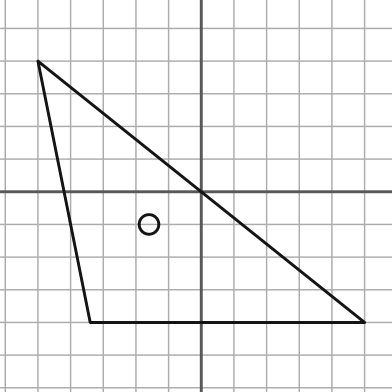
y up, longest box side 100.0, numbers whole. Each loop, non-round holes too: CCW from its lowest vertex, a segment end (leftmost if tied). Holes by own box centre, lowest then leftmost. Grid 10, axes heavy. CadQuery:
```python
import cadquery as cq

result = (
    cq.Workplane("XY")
    .moveTo(-34.0, -40.0)
    .lineTo(50.0, -40.0)
    .lineTo(-50.0, 40.0)
    .close()
    .moveTo(-16.0, -10.0)
    .circle(3.0)
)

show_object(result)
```